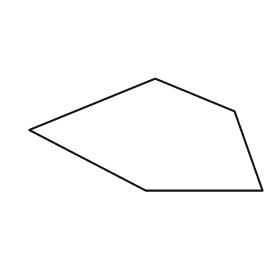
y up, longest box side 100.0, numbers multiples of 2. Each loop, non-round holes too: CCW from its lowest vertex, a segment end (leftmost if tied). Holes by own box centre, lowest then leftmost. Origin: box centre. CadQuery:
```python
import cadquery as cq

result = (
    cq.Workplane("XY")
    .moveTo(0.0, -24.0)
    .lineTo(50.0, -24.0)
    .lineTo(38.0, 10.0)
    .lineTo(4.0, 24.0)
    .lineTo(-50.0, 2.0)
    .close()
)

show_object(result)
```